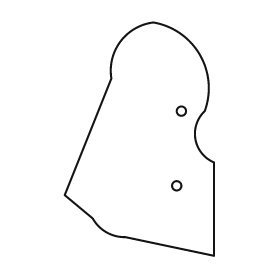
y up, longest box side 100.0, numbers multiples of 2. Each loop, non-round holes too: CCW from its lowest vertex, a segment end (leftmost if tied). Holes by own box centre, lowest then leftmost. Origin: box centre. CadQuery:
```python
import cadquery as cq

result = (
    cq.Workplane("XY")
    .moveTo(32.0, -50.0)
    .lineTo(32.0, -10.0)
    .threePointArc((24.0, 0.0), (28.0, 12.0))
    .threePointArc((26.0, 36.0), (6.0, 50.0))
    .threePointArc((-8.0, 42.0), (-12.0, 26.0))
    .lineTo(-32.0, -24.0)
    .lineTo(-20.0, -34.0)
    .threePointArc((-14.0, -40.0), (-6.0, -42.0))
    .close()
    .moveTo(16.0, -20.0)
    .circle(2.0)
    .moveTo(18.0, 12.0)
    .circle(2.0)
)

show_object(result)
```